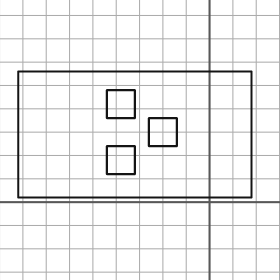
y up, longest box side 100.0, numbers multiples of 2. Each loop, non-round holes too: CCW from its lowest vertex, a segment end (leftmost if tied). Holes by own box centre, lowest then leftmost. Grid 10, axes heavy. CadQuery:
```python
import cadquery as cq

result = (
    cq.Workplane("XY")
    .moveTo(-82.0, 2.0)
    .lineTo(18.0, 2.0)
    .lineTo(18.0, 56.0)
    .lineTo(-82.0, 56.0)
    .close()
    .moveTo(-44.0, 12.0)
    .lineTo(-32.0, 12.0)
    .lineTo(-32.0, 24.0)
    .lineTo(-44.0, 24.0)
    .close()
    .moveTo(-26.0, 24.0)
    .lineTo(-14.0, 24.0)
    .lineTo(-14.0, 36.0)
    .lineTo(-26.0, 36.0)
    .close()
    .moveTo(-44.0, 36.0)
    .lineTo(-32.0, 36.0)
    .lineTo(-32.0, 48.0)
    .lineTo(-44.0, 48.0)
    .close()
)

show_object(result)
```